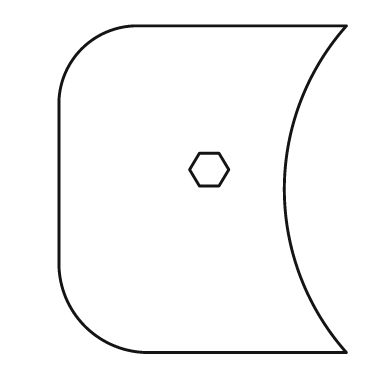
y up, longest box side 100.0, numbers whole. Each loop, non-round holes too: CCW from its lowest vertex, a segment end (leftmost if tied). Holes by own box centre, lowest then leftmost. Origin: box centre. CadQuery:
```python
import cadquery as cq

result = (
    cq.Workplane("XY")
    .moveTo(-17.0, -50.0)
    .lineTo(44.0, -50.0)
    .threePointArc((25.0, 0.0), (44.0, 50.0))
    .lineTo(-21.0, 50.0)
    .threePointArc((-37.0, 43.0), (-44.0, 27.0))
    .lineTo(-44.0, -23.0)
    .threePointArc((-36.0, -42.0), (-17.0, -50.0))
    .close()
    .moveTo(-1.0, 1.0)
    .lineTo(5.0, 1.0)
    .lineTo(8.0, 6.0)
    .lineTo(5.0, 11.0)
    .lineTo(-1.0, 11.0)
    .lineTo(-4.0, 6.0)
    .close()
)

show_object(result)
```